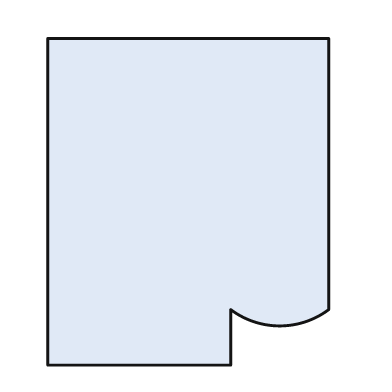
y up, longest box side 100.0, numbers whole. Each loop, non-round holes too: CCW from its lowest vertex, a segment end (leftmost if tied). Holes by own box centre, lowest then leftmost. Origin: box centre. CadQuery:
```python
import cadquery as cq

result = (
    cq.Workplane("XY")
    .moveTo(-43.0, -50.0)
    .lineTo(13.0, -50.0)
    .lineTo(13.0, -33.0)
    .threePointArc((28.0, -38.0), (43.0, -33.0))
    .lineTo(43.0, 50.0)
    .lineTo(-43.0, 50.0)
    .close()
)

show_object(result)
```